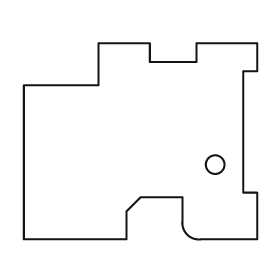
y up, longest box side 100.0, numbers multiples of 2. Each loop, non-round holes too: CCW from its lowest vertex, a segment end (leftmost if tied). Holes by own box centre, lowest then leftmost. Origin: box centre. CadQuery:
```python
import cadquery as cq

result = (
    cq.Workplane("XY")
    .moveTo(-50.0, -42.0)
    .lineTo(-6.0, -42.0)
    .lineTo(-6.0, -30.0)
    .lineTo(0.0, -24.0)
    .lineTo(18.0, -24.0)
    .lineTo(18.0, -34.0)
    .threePointArc((20.0, -40.0), (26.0, -42.0))
    .lineTo(50.0, -42.0)
    .lineTo(50.0, -22.0)
    .lineTo(44.0, -22.0)
    .lineTo(44.0, 30.0)
    .lineTo(50.0, 30.0)
    .lineTo(50.0, 42.0)
    .lineTo(24.0, 42.0)
    .lineTo(24.0, 34.0)
    .lineTo(4.0, 34.0)
    .lineTo(4.0, 42.0)
    .lineTo(-18.0, 42.0)
    .lineTo(-18.0, 24.0)
    .lineTo(-50.0, 24.0)
    .close()
    .moveTo(32.0, -10.0)
    .circle(4.0)
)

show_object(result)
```